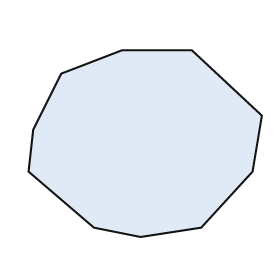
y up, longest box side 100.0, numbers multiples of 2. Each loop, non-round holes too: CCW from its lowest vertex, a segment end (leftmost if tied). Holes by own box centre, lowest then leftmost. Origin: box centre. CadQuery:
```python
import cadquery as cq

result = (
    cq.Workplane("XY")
    .moveTo(-2.0, -40.0)
    .lineTo(24.0, -36.0)
    .lineTo(46.0, -12.0)
    .lineTo(50.0, 12.0)
    .lineTo(20.0, 40.0)
    .lineTo(-10.0, 40.0)
    .lineTo(-36.0, 30.0)
    .lineTo(-48.0, 6.0)
    .lineTo(-50.0, -12.0)
    .lineTo(-22.0, -36.0)
    .close()
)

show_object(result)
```